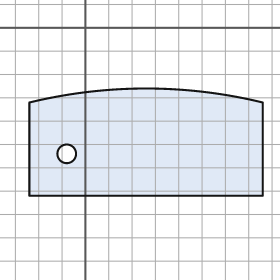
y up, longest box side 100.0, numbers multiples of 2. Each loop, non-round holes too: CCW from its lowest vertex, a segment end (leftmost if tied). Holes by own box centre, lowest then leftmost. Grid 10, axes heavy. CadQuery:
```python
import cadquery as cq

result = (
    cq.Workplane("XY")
    .moveTo(-24.0, -72.0)
    .lineTo(76.0, -72.0)
    .lineTo(76.0, -32.0)
    .threePointArc((26.0, -26.0), (-24.0, -32.0))
    .close()
    .moveTo(-8.0, -54.0)
    .circle(4.0)
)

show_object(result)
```